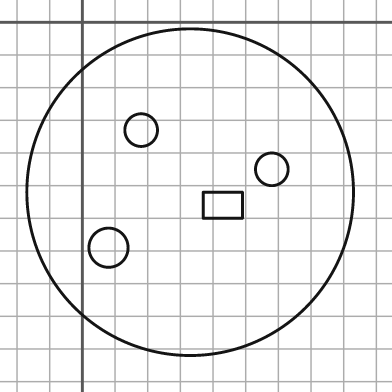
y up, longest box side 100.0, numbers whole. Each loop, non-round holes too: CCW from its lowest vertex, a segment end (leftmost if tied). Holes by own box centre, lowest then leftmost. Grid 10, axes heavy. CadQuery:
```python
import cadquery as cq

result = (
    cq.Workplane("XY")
    .moveTo(33.0, -52.0)
    .circle(50.0)
    .moveTo(8.0, -69.0)
    .circle(6.0)
    .moveTo(37.0, -60.0)
    .lineTo(49.0, -60.0)
    .lineTo(49.0, -52.0)
    .lineTo(37.0, -52.0)
    .close()
    .moveTo(58.0, -45.0)
    .circle(5.0)
    .moveTo(18.0, -33.0)
    .circle(5.0)
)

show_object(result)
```